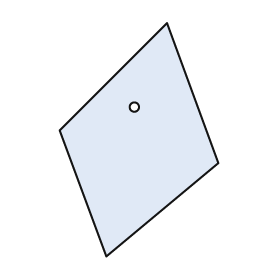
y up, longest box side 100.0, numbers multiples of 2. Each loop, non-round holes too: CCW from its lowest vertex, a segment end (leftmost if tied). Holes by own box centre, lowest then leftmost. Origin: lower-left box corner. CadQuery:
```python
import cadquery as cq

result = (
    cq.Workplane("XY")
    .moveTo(20.0, 0.0)
    .lineTo(68.0, 40.0)
    .lineTo(46.0, 100.0)
    .lineTo(0.0, 54.0)
    .close()
    .moveTo(32.0, 64.0)
    .circle(2.0)
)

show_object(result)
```